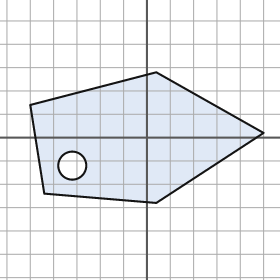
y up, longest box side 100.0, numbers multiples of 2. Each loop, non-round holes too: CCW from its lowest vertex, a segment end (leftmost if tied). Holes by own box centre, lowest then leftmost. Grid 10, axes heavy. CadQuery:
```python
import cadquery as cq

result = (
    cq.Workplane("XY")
    .moveTo(4.0, -28.0)
    .lineTo(50.0, 2.0)
    .lineTo(4.0, 28.0)
    .lineTo(-50.0, 14.0)
    .lineTo(-44.0, -24.0)
    .close()
    .moveTo(-32.0, -12.0)
    .circle(6.0)
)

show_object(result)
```